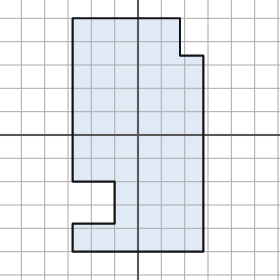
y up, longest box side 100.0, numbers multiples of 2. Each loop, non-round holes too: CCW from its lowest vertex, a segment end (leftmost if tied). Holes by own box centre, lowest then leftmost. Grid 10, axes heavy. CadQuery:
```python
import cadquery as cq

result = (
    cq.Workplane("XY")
    .moveTo(-28.0, -50.0)
    .lineTo(28.0, -50.0)
    .lineTo(28.0, 34.0)
    .lineTo(18.0, 34.0)
    .lineTo(18.0, 50.0)
    .lineTo(-28.0, 50.0)
    .lineTo(-28.0, -20.0)
    .lineTo(-10.0, -20.0)
    .lineTo(-10.0, -38.0)
    .lineTo(-28.0, -38.0)
    .close()
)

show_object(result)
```